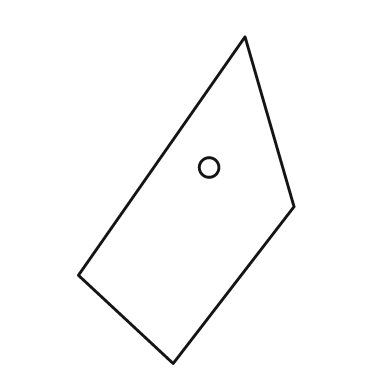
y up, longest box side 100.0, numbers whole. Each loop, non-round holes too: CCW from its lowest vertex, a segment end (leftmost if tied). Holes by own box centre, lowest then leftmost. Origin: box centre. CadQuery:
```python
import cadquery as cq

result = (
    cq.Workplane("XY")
    .moveTo(-4.0, -50.0)
    .lineTo(33.0, -2.0)
    .lineTo(18.0, 50.0)
    .lineTo(-33.0, -23.0)
    .close()
    .moveTo(7.0, 10.0)
    .circle(3.0)
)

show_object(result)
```